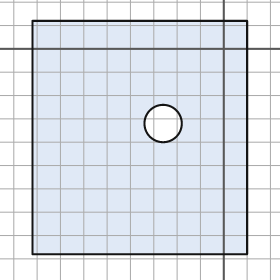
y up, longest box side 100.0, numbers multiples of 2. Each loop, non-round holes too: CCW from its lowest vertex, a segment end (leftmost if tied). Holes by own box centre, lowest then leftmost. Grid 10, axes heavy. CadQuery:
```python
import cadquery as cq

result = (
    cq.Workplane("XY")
    .moveTo(-82.0, -88.0)
    .lineTo(10.0, -88.0)
    .lineTo(10.0, 12.0)
    .lineTo(-82.0, 12.0)
    .close()
    .moveTo(-26.0, -32.0)
    .circle(8.0)
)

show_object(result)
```